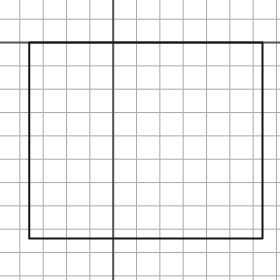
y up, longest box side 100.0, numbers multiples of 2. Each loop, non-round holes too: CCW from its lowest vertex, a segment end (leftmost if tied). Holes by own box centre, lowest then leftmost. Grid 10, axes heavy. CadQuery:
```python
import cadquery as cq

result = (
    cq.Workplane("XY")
    .moveTo(-36.0, -84.0)
    .lineTo(64.0, -84.0)
    .lineTo(64.0, 0.0)
    .lineTo(-36.0, 0.0)
    .close()
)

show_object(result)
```